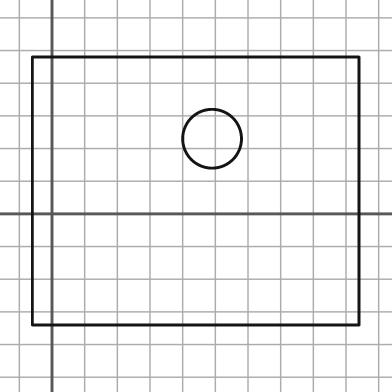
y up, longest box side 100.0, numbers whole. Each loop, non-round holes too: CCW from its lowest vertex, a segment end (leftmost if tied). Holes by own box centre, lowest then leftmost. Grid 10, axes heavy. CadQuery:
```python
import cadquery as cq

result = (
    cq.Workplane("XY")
    .moveTo(-6.0, -34.0)
    .lineTo(94.0, -34.0)
    .lineTo(94.0, 48.0)
    .lineTo(-6.0, 48.0)
    .close()
    .moveTo(49.0, 23.0)
    .circle(9.0)
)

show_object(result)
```